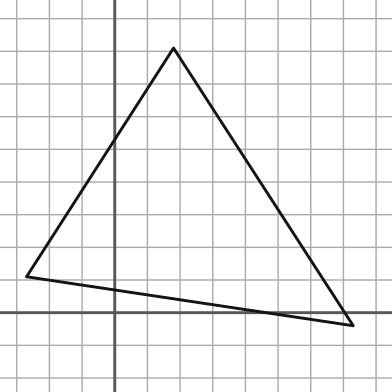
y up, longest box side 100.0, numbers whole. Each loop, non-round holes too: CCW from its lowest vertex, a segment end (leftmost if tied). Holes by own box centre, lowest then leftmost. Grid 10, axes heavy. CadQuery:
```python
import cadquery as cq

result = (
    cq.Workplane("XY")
    .moveTo(73.0, -4.0)
    .lineTo(18.0, 81.0)
    .lineTo(-27.0, 11.0)
    .close()
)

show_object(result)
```